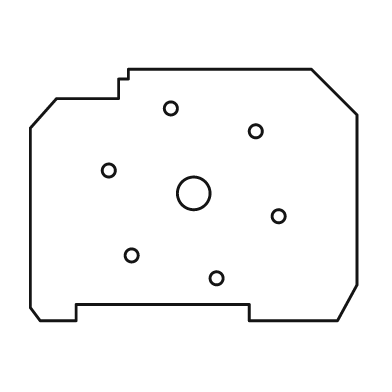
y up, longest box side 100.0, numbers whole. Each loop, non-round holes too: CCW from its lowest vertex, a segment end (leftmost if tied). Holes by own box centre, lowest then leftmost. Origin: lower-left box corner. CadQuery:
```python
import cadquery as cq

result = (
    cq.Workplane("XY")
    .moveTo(3.0, 0.0)
    .lineTo(14.0, 0.0)
    .lineTo(14.0, 5.0)
    .lineTo(67.0, 5.0)
    .lineTo(67.0, 0.0)
    .lineTo(94.0, 0.0)
    .lineTo(100.0, 11.0)
    .lineTo(100.0, 63.0)
    .lineTo(86.0, 77.0)
    .lineTo(30.0, 77.0)
    .lineTo(30.0, 74.0)
    .lineTo(27.0, 74.0)
    .lineTo(27.0, 68.0)
    .lineTo(8.0, 68.0)
    .lineTo(0.0, 59.0)
    .lineTo(0.0, 4.0)
    .close()
    .moveTo(57.0, 13.0)
    .circle(2.0)
    .moveTo(31.0, 20.0)
    .circle(2.0)
    .moveTo(76.0, 32.0)
    .circle(2.0)
    .moveTo(50.0, 39.0)
    .circle(5.0)
    .moveTo(24.0, 46.0)
    .circle(2.0)
    .moveTo(69.0, 58.0)
    .circle(2.0)
    .moveTo(43.0, 65.0)
    .circle(2.0)
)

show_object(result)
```